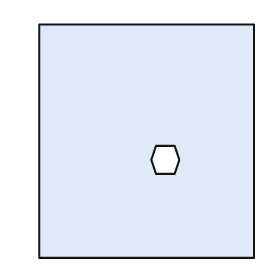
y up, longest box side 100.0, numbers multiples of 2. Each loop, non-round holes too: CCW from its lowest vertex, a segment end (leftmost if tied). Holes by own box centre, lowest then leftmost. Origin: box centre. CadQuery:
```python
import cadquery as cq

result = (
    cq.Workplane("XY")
    .moveTo(-46.0, -50.0)
    .lineTo(46.0, -50.0)
    .lineTo(46.0, 50.0)
    .lineTo(-46.0, 50.0)
    .close()
    .moveTo(4.0, -14.0)
    .lineTo(12.0, -14.0)
    .lineTo(14.0, -8.0)
    .lineTo(12.0, -2.0)
    .lineTo(4.0, -2.0)
    .lineTo(2.0, -8.0)
    .close()
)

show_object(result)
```